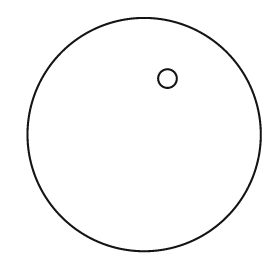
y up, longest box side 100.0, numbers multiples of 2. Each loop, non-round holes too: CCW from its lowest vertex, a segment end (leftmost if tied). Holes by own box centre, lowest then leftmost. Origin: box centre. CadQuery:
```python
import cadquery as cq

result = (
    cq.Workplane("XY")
    .moveTo(0.0, 0.0)
    .circle(50.0)
    .moveTo(10.0, 24.0)
    .circle(4.0)
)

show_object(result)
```